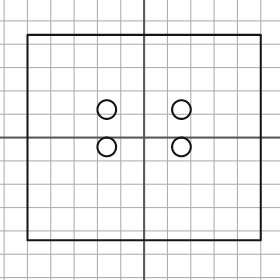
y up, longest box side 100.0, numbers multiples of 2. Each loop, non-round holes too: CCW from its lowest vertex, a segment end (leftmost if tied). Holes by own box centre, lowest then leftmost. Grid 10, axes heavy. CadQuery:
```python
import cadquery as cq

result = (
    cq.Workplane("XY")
    .moveTo(-50.0, -44.0)
    .lineTo(50.0, -44.0)
    .lineTo(50.0, 44.0)
    .lineTo(-50.0, 44.0)
    .close()
    .moveTo(-16.0, -4.0)
    .circle(4.0)
    .moveTo(16.0, -4.0)
    .circle(4.0)
    .moveTo(-16.0, 12.0)
    .circle(4.0)
    .moveTo(16.0, 12.0)
    .circle(4.0)
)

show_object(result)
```